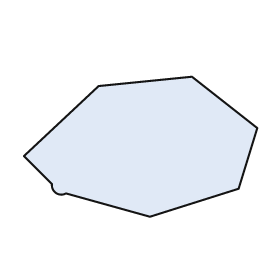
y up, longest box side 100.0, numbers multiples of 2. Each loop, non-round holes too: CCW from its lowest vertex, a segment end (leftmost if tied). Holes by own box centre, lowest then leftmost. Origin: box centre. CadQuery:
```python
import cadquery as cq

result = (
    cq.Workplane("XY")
    .moveTo(4.0, -30.0)
    .lineTo(42.0, -18.0)
    .lineTo(50.0, 8.0)
    .lineTo(22.0, 30.0)
    .lineTo(-18.0, 26.0)
    .lineTo(-50.0, -4.0)
    .lineTo(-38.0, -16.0)
    .threePointArc((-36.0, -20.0), (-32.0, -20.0))
    .close()
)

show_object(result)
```